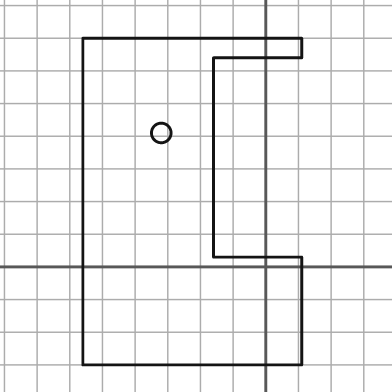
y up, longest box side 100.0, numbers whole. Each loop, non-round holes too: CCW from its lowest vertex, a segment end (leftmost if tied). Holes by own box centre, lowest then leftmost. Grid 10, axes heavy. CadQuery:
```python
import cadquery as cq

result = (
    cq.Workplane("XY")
    .moveTo(-56.0, -30.0)
    .lineTo(11.0, -30.0)
    .lineTo(11.0, 3.0)
    .lineTo(-16.0, 3.0)
    .lineTo(-16.0, 64.0)
    .lineTo(11.0, 64.0)
    .lineTo(11.0, 70.0)
    .lineTo(-56.0, 70.0)
    .close()
    .moveTo(-32.0, 41.0)
    .circle(3.0)
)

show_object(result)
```